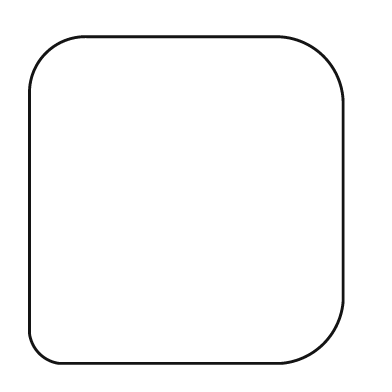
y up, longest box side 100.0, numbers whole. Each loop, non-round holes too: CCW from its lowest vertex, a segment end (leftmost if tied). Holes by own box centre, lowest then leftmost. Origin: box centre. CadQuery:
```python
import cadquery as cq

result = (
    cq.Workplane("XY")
    .moveTo(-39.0, -50.0)
    .lineTo(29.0, -50.0)
    .threePointArc((42.0, -44.0), (48.0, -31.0))
    .lineTo(48.0, 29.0)
    .threePointArc((42.0, 44.0), (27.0, 50.0))
    .lineTo(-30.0, 50.0)
    .threePointArc((-43.0, 45.0), (-48.0, 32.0))
    .lineTo(-48.0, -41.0)
    .threePointArc((-45.0, -47.0), (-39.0, -50.0))
    .close()
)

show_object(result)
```